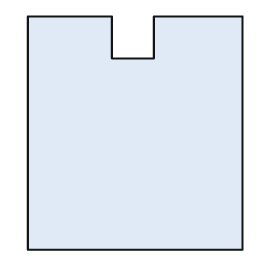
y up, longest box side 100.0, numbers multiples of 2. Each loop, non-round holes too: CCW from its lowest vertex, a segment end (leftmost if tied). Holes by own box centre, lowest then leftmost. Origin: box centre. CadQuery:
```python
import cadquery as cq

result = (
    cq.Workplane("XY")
    .moveTo(-46.0, -50.0)
    .lineTo(46.0, -50.0)
    .lineTo(46.0, 50.0)
    .lineTo(8.0, 50.0)
    .lineTo(8.0, 32.0)
    .lineTo(-10.0, 32.0)
    .lineTo(-10.0, 50.0)
    .lineTo(-46.0, 50.0)
    .close()
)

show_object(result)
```